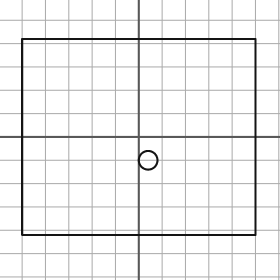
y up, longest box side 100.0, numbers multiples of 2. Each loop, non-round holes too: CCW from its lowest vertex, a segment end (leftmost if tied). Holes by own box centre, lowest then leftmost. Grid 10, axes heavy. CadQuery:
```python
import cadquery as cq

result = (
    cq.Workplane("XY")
    .moveTo(-50.0, -42.0)
    .lineTo(50.0, -42.0)
    .lineTo(50.0, 42.0)
    .lineTo(-50.0, 42.0)
    .close()
    .moveTo(4.0, -10.0)
    .circle(4.0)
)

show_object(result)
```